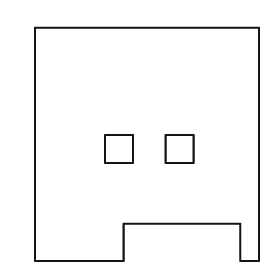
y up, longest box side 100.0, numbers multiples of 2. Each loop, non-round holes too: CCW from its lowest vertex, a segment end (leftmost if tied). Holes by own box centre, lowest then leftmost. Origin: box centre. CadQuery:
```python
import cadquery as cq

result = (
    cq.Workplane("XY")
    .moveTo(-48.0, -50.0)
    .lineTo(-10.0, -50.0)
    .lineTo(-10.0, -34.0)
    .lineTo(40.0, -34.0)
    .lineTo(40.0, -50.0)
    .lineTo(48.0, -50.0)
    .lineTo(48.0, 50.0)
    .lineTo(-48.0, 50.0)
    .close()
    .moveTo(-18.0, -8.0)
    .lineTo(-6.0, -8.0)
    .lineTo(-6.0, 4.0)
    .lineTo(-18.0, 4.0)
    .close()
    .moveTo(8.0, -8.0)
    .lineTo(20.0, -8.0)
    .lineTo(20.0, 4.0)
    .lineTo(8.0, 4.0)
    .close()
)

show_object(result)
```